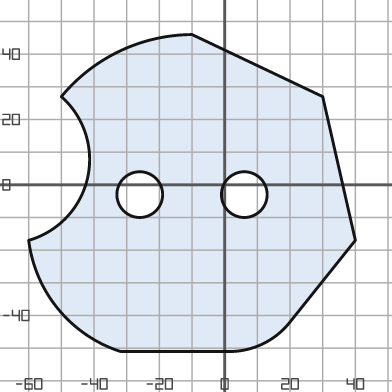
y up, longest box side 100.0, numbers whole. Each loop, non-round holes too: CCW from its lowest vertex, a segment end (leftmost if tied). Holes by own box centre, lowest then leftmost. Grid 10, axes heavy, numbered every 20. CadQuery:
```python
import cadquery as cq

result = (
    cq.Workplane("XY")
    .moveTo(-32.0, -51.0)
    .lineTo(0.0, -51.0)
    .threePointArc((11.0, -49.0), (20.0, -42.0))
    .lineTo(40.0, -17.0)
    .lineTo(30.0, 27.0)
    .lineTo(-10.0, 46.0)
    .threePointArc((-32.0, 41.0), (-50.0, 27.0))
    .threePointArc((-42.0, 2.0), (-60.0, -17.0))
    .threePointArc((-51.0, -38.0), (-32.0, -51.0))
    .close()
    .moveTo(-26.0, -3.0)
    .circle(7.0)
    .moveTo(6.0, -3.0)
    .circle(7.0)
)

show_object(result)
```